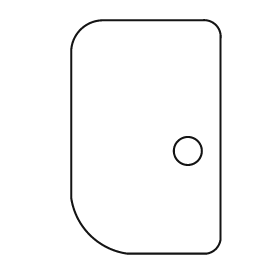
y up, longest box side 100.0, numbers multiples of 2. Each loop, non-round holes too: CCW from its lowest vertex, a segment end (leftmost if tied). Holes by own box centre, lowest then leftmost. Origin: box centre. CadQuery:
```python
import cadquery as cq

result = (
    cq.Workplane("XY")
    .moveTo(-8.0, -50.0)
    .lineTo(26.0, -50.0)
    .threePointArc((30.0, -48.0), (32.0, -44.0))
    .lineTo(32.0, 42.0)
    .threePointArc((30.0, 48.0), (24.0, 50.0))
    .lineTo(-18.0, 50.0)
    .threePointArc((-28.0, 46.0), (-32.0, 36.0))
    .lineTo(-32.0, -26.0)
    .threePointArc((-24.0, -42.0), (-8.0, -50.0))
    .close()
    .moveTo(18.0, -6.0)
    .circle(6.0)
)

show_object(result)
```